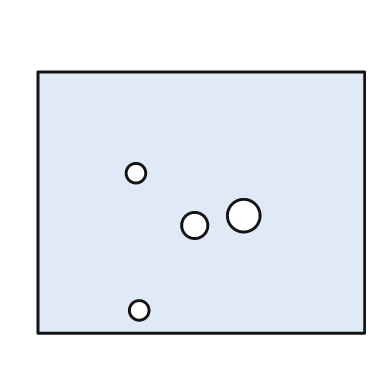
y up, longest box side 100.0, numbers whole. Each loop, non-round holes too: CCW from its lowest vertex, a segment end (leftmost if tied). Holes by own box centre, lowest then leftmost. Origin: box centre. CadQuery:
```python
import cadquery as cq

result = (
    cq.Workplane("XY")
    .moveTo(-50.0, -40.0)
    .lineTo(50.0, -40.0)
    .lineTo(50.0, 40.0)
    .lineTo(-50.0, 40.0)
    .close()
    .moveTo(-19.0, -33.0)
    .circle(3.0)
    .moveTo(-2.0, -7.0)
    .circle(4.0)
    .moveTo(13.0, -4.0)
    .circle(5.0)
    .moveTo(-20.0, 9.0)
    .circle(3.0)
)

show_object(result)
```